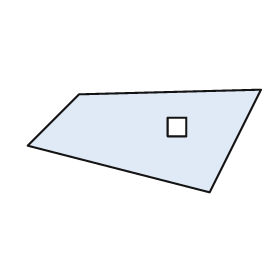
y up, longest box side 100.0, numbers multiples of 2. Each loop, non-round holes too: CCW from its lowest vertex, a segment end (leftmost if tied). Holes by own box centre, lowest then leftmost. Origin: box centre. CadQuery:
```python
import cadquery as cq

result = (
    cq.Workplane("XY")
    .moveTo(28.0, -22.0)
    .lineTo(50.0, 22.0)
    .lineTo(-28.0, 20.0)
    .lineTo(-50.0, -2.0)
    .close()
    .moveTo(10.0, 2.0)
    .lineTo(18.0, 2.0)
    .lineTo(18.0, 10.0)
    .lineTo(10.0, 10.0)
    .close()
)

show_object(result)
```